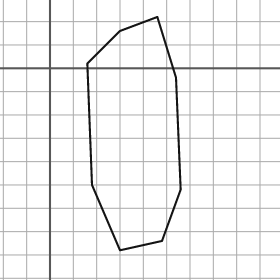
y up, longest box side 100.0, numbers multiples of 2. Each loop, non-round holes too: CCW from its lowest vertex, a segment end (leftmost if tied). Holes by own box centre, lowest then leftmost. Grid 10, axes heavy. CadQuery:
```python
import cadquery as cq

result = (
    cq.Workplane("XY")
    .moveTo(30.0, -78.0)
    .lineTo(48.0, -74.0)
    .lineTo(56.0, -52.0)
    .lineTo(54.0, -4.0)
    .lineTo(46.0, 22.0)
    .lineTo(30.0, 16.0)
    .lineTo(16.0, 2.0)
    .lineTo(18.0, -50.0)
    .close()
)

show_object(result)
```